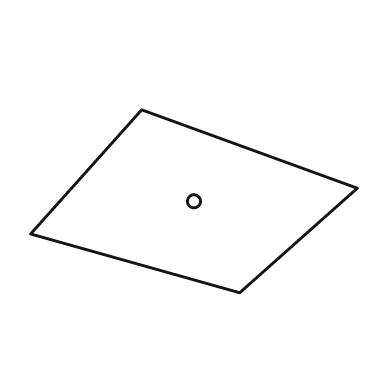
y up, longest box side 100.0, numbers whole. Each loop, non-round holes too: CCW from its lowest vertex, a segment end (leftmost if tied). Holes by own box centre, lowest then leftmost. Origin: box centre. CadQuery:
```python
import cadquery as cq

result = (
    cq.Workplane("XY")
    .moveTo(14.0, -28.0)
    .lineTo(50.0, 4.0)
    .lineTo(-16.0, 28.0)
    .lineTo(-50.0, -10.0)
    .close()
    .moveTo(0.0, 0.0)
    .circle(2.0)
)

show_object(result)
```